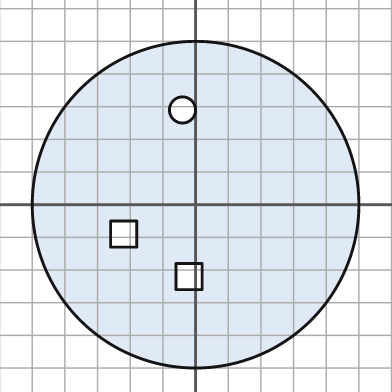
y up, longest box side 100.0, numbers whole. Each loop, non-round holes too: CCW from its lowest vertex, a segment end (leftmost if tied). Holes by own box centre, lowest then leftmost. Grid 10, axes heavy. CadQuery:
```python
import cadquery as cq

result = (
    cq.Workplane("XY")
    .moveTo(0.0, 0.0)
    .circle(50.0)
    .moveTo(-6.0, -26.0)
    .lineTo(2.0, -26.0)
    .lineTo(2.0, -18.0)
    .lineTo(-6.0, -18.0)
    .close()
    .moveTo(-26.0, -13.0)
    .lineTo(-18.0, -13.0)
    .lineTo(-18.0, -5.0)
    .lineTo(-26.0, -5.0)
    .close()
    .moveTo(-4.0, 29.0)
    .circle(4.0)
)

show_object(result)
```